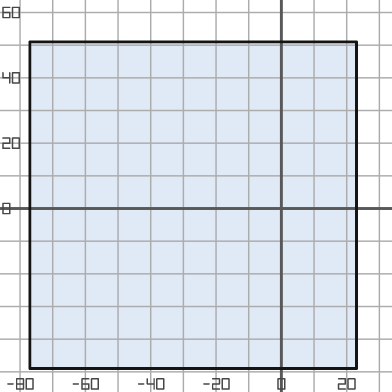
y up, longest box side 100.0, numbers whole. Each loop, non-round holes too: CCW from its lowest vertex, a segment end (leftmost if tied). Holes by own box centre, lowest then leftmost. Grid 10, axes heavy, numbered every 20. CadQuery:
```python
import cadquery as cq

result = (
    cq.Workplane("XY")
    .moveTo(-77.0, -49.0)
    .lineTo(23.0, -49.0)
    .lineTo(23.0, 51.0)
    .lineTo(-77.0, 51.0)
    .close()
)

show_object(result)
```